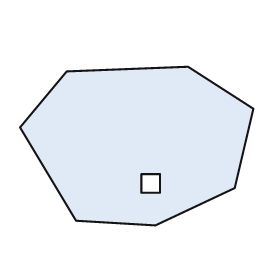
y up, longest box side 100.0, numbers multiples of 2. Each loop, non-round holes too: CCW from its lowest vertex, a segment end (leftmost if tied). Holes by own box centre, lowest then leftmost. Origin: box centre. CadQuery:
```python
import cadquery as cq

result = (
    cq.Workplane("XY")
    .moveTo(8.0, -34.0)
    .lineTo(42.0, -18.0)
    .lineTo(50.0, 16.0)
    .lineTo(22.0, 34.0)
    .lineTo(-30.0, 32.0)
    .lineTo(-50.0, 8.0)
    .lineTo(-26.0, -32.0)
    .close()
    .moveTo(2.0, -20.0)
    .lineTo(10.0, -20.0)
    .lineTo(10.0, -12.0)
    .lineTo(2.0, -12.0)
    .close()
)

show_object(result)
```